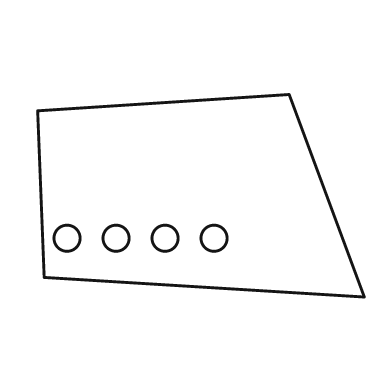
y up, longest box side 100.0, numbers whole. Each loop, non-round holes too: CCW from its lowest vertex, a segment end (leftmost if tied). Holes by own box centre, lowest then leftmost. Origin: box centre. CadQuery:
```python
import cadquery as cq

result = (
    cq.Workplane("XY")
    .moveTo(50.0, -31.0)
    .lineTo(27.0, 31.0)
    .lineTo(-50.0, 26.0)
    .lineTo(-48.0, -25.0)
    .close()
    .moveTo(-41.0, -13.0)
    .circle(4.0)
    .moveTo(-26.0, -13.0)
    .circle(4.0)
    .moveTo(-11.0, -13.0)
    .circle(4.0)
    .moveTo(4.0, -13.0)
    .circle(4.0)
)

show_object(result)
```